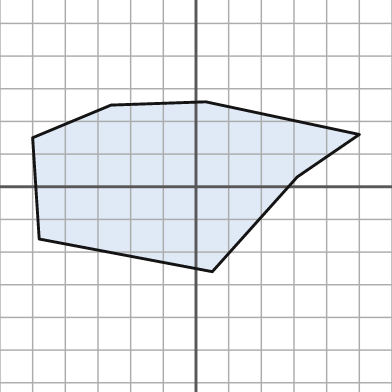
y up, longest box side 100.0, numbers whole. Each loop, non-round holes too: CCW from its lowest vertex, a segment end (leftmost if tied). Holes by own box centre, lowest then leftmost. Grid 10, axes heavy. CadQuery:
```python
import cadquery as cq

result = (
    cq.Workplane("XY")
    .moveTo(5.0, -26.0)
    .lineTo(31.0, 3.0)
    .lineTo(50.0, 16.0)
    .lineTo(3.0, 26.0)
    .lineTo(-26.0, 25.0)
    .lineTo(-50.0, 15.0)
    .lineTo(-48.0, -16.0)
    .close()
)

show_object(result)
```